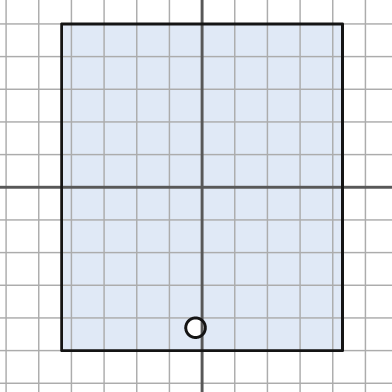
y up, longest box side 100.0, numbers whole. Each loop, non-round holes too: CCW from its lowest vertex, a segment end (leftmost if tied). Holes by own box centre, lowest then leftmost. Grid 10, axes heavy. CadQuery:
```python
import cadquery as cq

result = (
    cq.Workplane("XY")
    .moveTo(-43.0, -50.0)
    .lineTo(43.0, -50.0)
    .lineTo(43.0, 50.0)
    .lineTo(-43.0, 50.0)
    .close()
    .moveTo(-2.0, -43.0)
    .circle(3.0)
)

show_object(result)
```